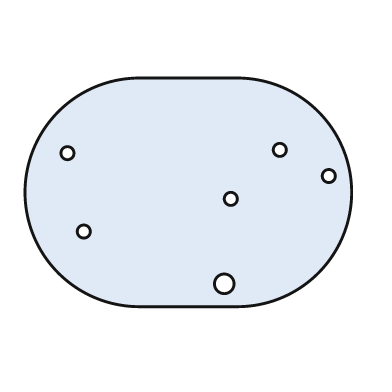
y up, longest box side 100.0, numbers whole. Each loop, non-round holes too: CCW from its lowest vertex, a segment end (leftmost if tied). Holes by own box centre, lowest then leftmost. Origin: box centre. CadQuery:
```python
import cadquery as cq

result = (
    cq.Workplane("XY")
    .moveTo(-15.0, -35.0)
    .lineTo(15.0, -35.0)
    .threePointArc((50.0, 0.0), (15.0, 35.0))
    .lineTo(-15.0, 35.0)
    .threePointArc((-50.0, 0.0), (-15.0, -35.0))
    .close()
    .moveTo(11.0, -28.0)
    .circle(3.0)
    .moveTo(-32.0, -12.0)
    .circle(2.0)
    .moveTo(13.0, -2.0)
    .circle(2.0)
    .moveTo(43.0, 5.0)
    .circle(2.0)
    .moveTo(-37.0, 12.0)
    .circle(2.0)
    .moveTo(28.0, 13.0)
    .circle(2.0)
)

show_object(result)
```